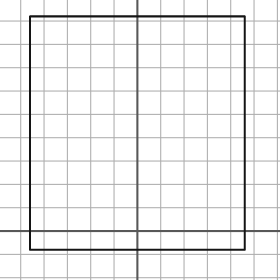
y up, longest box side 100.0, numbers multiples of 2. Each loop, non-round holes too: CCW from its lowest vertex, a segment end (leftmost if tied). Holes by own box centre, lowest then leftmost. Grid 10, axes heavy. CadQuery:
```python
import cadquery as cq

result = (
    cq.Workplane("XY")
    .moveTo(-46.0, -8.0)
    .lineTo(46.0, -8.0)
    .lineTo(46.0, 92.0)
    .lineTo(-46.0, 92.0)
    .close()
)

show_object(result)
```